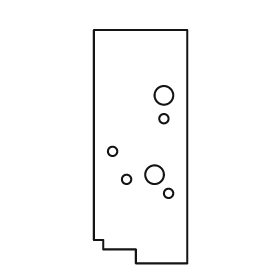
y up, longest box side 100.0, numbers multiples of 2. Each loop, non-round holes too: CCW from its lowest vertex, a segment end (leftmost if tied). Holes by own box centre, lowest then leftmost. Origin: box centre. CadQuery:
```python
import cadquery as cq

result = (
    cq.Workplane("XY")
    .moveTo(-2.0, -50.0)
    .lineTo(20.0, -50.0)
    .lineTo(20.0, 50.0)
    .lineTo(-20.0, 50.0)
    .lineTo(-20.0, -40.0)
    .lineTo(-16.0, -40.0)
    .lineTo(-16.0, -44.0)
    .lineTo(-2.0, -44.0)
    .close()
    .moveTo(12.0, -20.0)
    .circle(2.0)
    .moveTo(-6.0, -14.0)
    .circle(2.0)
    .moveTo(6.0, -12.0)
    .circle(4.0)
    .moveTo(-12.0, -2.0)
    .circle(2.0)
    .moveTo(10.0, 12.0)
    .circle(2.0)
    .moveTo(10.0, 22.0)
    .circle(4.0)
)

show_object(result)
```